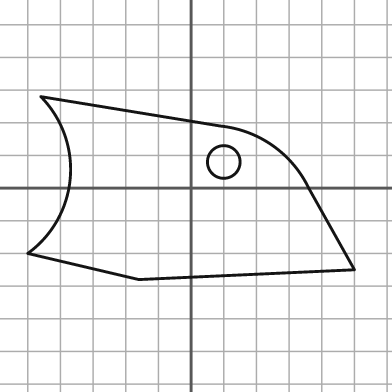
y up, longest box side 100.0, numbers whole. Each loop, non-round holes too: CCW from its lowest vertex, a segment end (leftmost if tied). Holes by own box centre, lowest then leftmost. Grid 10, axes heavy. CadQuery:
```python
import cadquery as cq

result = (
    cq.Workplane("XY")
    .moveTo(-16.0, -28.0)
    .lineTo(50.0, -25.0)
    .lineTo(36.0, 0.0)
    .threePointArc((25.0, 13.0), (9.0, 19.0))
    .lineTo(-46.0, 28.0)
    .threePointArc((-37.0, 3.0), (-50.0, -20.0))
    .close()
    .moveTo(10.0, 8.0)
    .circle(5.0)
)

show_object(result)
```